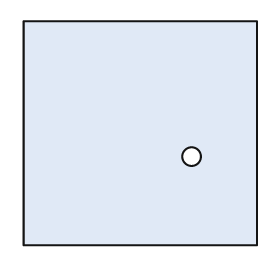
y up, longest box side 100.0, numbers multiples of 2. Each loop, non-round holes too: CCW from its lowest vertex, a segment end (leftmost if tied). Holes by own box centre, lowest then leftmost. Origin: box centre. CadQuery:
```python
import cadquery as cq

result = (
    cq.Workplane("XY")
    .moveTo(-50.0, -48.0)
    .lineTo(50.0, -48.0)
    .lineTo(50.0, 48.0)
    .lineTo(-50.0, 48.0)
    .close()
    .moveTo(22.0, -10.0)
    .circle(4.0)
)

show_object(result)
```